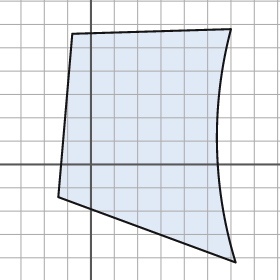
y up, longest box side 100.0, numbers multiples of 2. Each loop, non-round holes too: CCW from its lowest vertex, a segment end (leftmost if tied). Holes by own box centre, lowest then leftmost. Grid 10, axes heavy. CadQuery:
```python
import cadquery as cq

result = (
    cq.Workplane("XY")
    .moveTo(62.0, -42.0)
    .threePointArc((54.0, 8.0), (60.0, 58.0))
    .lineTo(-8.0, 56.0)
    .lineTo(-14.0, -14.0)
    .close()
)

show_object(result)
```